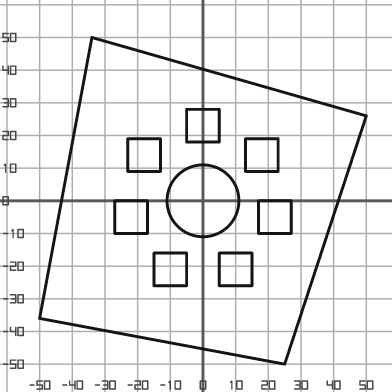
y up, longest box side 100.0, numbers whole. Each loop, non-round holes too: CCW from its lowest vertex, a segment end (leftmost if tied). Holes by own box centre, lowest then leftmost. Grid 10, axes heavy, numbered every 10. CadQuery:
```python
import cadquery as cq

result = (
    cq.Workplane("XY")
    .moveTo(25.0, -50.0)
    .lineTo(50.0, 26.0)
    .lineTo(-34.0, 50.0)
    .lineTo(-50.0, -36.0)
    .close()
    .moveTo(-15.0, -26.0)
    .lineTo(-5.0, -26.0)
    .lineTo(-5.0, -16.0)
    .lineTo(-15.0, -16.0)
    .close()
    .moveTo(5.0, -26.0)
    .lineTo(15.0, -26.0)
    .lineTo(15.0, -16.0)
    .lineTo(5.0, -16.0)
    .close()
    .moveTo(-27.0, -10.0)
    .lineTo(-17.0, -10.0)
    .lineTo(-17.0, 0.0)
    .lineTo(-27.0, 0.0)
    .close()
    .moveTo(17.0, -10.0)
    .lineTo(27.0, -10.0)
    .lineTo(27.0, 0.0)
    .lineTo(17.0, 0.0)
    .close()
    .moveTo(0.0, 0.0)
    .circle(11.0)
    .moveTo(-23.0, 9.0)
    .lineTo(-13.0, 9.0)
    .lineTo(-13.0, 19.0)
    .lineTo(-23.0, 19.0)
    .close()
    .moveTo(13.0, 9.0)
    .lineTo(23.0, 9.0)
    .lineTo(23.0, 19.0)
    .lineTo(13.0, 19.0)
    .close()
    .moveTo(-5.0, 18.0)
    .lineTo(5.0, 18.0)
    .lineTo(5.0, 28.0)
    .lineTo(-5.0, 28.0)
    .close()
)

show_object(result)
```